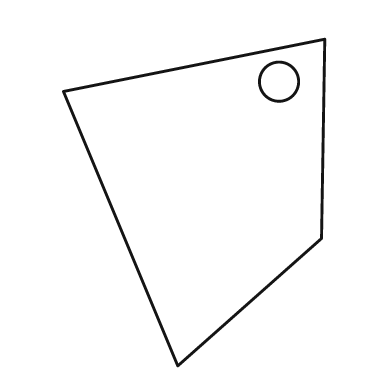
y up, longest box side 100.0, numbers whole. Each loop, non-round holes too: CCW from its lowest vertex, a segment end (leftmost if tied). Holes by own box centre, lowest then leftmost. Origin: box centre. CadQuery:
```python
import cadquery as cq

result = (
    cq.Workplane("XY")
    .moveTo(-5.0, -50.0)
    .lineTo(39.0, -11.0)
    .lineTo(40.0, 50.0)
    .lineTo(-40.0, 34.0)
    .close()
    .moveTo(26.0, 37.0)
    .circle(6.0)
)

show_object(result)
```